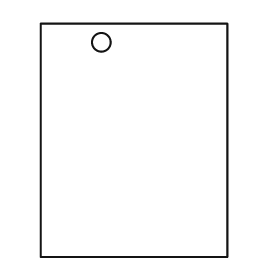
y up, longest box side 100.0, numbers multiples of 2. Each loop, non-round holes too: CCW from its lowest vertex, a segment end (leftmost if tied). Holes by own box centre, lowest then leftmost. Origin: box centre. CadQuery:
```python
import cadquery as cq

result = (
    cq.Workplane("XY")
    .moveTo(-40.0, -50.0)
    .lineTo(40.0, -50.0)
    .lineTo(40.0, 50.0)
    .lineTo(-40.0, 50.0)
    .close()
    .moveTo(-14.0, 42.0)
    .circle(4.0)
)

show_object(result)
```